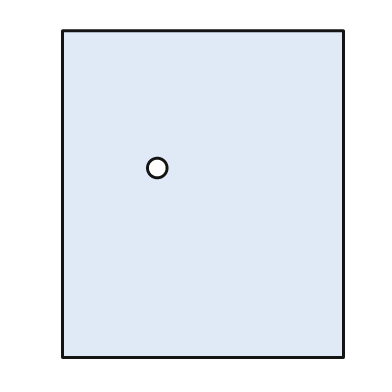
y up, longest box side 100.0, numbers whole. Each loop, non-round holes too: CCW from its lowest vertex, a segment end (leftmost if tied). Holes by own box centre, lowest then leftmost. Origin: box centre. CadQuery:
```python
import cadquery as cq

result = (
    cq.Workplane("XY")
    .moveTo(-43.0, -50.0)
    .lineTo(43.0, -50.0)
    .lineTo(43.0, 50.0)
    .lineTo(-43.0, 50.0)
    .close()
    .moveTo(-14.0, 8.0)
    .circle(3.0)
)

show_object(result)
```